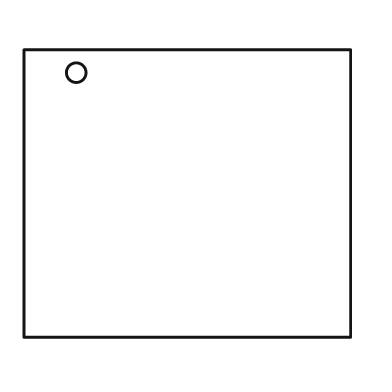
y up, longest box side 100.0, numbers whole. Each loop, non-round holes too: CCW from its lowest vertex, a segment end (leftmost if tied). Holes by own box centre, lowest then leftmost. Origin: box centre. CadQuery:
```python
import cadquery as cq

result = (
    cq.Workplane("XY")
    .moveTo(-50.0, -44.0)
    .lineTo(50.0, -44.0)
    .lineTo(50.0, 44.0)
    .lineTo(-50.0, 44.0)
    .close()
    .moveTo(-34.0, 37.0)
    .circle(3.0)
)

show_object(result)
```